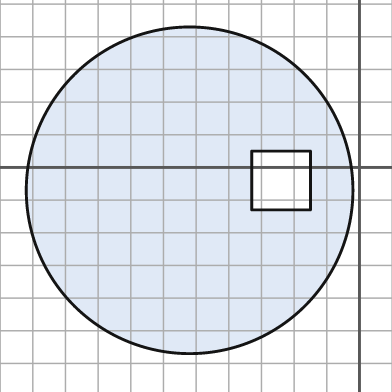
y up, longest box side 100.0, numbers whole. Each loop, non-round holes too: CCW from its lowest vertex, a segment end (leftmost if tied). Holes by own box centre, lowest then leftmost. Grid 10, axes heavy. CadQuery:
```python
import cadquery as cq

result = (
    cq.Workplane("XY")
    .moveTo(-52.0, -7.0)
    .circle(50.0)
    .moveTo(-33.0, -13.0)
    .lineTo(-15.0, -13.0)
    .lineTo(-15.0, 5.0)
    .lineTo(-33.0, 5.0)
    .close()
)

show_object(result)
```